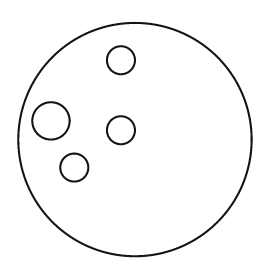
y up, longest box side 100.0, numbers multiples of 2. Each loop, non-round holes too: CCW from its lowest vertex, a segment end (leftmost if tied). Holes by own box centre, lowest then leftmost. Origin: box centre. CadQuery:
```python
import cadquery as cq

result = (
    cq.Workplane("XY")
    .moveTo(0.0, 0.0)
    .circle(50.0)
    .moveTo(-26.0, -12.0)
    .circle(6.0)
    .moveTo(-6.0, 4.0)
    .circle(6.0)
    .moveTo(-36.0, 8.0)
    .circle(8.0)
    .moveTo(-6.0, 34.0)
    .circle(6.0)
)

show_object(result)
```